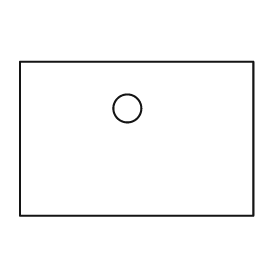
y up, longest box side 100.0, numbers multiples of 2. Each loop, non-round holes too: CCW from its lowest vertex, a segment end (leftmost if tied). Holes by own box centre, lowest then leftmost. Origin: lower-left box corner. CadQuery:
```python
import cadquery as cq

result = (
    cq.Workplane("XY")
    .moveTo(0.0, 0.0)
    .lineTo(100.0, 0.0)
    .lineTo(100.0, 66.0)
    .lineTo(0.0, 66.0)
    .close()
    .moveTo(46.0, 46.0)
    .circle(6.0)
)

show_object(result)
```